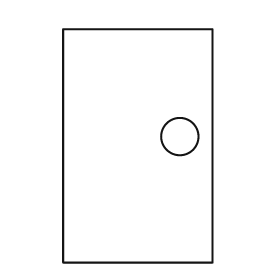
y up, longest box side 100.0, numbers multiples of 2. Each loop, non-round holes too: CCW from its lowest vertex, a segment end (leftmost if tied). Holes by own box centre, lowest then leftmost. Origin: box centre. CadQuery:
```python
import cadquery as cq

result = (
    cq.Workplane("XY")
    .moveTo(-32.0, -50.0)
    .lineTo(32.0, -50.0)
    .lineTo(32.0, 50.0)
    .lineTo(-32.0, 50.0)
    .close()
    .moveTo(18.0, 4.0)
    .circle(8.0)
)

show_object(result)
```